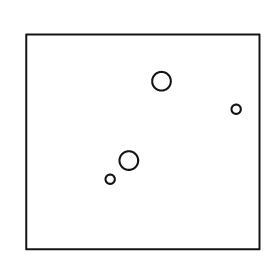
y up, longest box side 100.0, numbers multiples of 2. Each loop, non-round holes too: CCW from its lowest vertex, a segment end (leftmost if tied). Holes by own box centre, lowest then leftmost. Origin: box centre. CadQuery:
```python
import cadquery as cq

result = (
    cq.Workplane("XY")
    .moveTo(-50.0, -46.0)
    .lineTo(50.0, -46.0)
    .lineTo(50.0, 46.0)
    .lineTo(-50.0, 46.0)
    .close()
    .moveTo(-14.0, -16.0)
    .circle(2.0)
    .moveTo(-6.0, -8.0)
    .circle(4.0)
    .moveTo(40.0, 14.0)
    .circle(2.0)
    .moveTo(8.0, 26.0)
    .circle(4.0)
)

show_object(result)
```